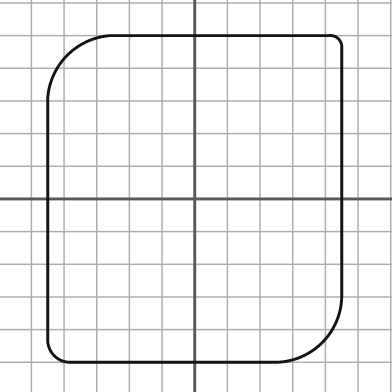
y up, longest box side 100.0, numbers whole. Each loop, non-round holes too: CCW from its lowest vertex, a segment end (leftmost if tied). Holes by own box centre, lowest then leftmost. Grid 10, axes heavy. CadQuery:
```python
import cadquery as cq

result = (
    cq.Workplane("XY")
    .moveTo(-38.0, -50.0)
    .lineTo(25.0, -50.0)
    .threePointArc((39.0, -44.0), (45.0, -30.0))
    .lineTo(45.0, 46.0)
    .threePointArc((44.0, 49.0), (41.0, 50.0))
    .lineTo(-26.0, 50.0)
    .threePointArc((-39.0, 44.0), (-45.0, 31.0))
    .lineTo(-45.0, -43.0)
    .threePointArc((-43.0, -48.0), (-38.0, -50.0))
    .close()
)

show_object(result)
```